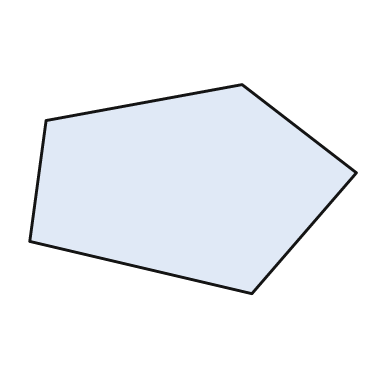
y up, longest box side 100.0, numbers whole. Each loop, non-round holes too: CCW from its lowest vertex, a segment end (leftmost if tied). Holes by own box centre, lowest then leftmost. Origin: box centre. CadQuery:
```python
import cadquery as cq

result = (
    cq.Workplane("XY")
    .moveTo(18.0, -32.0)
    .lineTo(50.0, 5.0)
    .lineTo(15.0, 32.0)
    .lineTo(-45.0, 21.0)
    .lineTo(-50.0, -16.0)
    .close()
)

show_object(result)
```